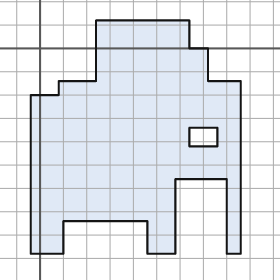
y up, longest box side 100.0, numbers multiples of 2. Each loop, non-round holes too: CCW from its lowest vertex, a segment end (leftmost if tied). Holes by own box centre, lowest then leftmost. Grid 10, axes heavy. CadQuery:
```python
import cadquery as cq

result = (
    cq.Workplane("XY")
    .moveTo(-4.0, -88.0)
    .lineTo(10.0, -88.0)
    .lineTo(10.0, -74.0)
    .lineTo(46.0, -74.0)
    .lineTo(46.0, -88.0)
    .lineTo(58.0, -88.0)
    .lineTo(58.0, -56.0)
    .lineTo(80.0, -56.0)
    .lineTo(80.0, -88.0)
    .lineTo(86.0, -88.0)
    .lineTo(86.0, -14.0)
    .lineTo(72.0, -14.0)
    .lineTo(72.0, 0.0)
    .lineTo(64.0, 0.0)
    .lineTo(64.0, 12.0)
    .lineTo(24.0, 12.0)
    .lineTo(24.0, -14.0)
    .lineTo(8.0, -14.0)
    .lineTo(8.0, -20.0)
    .lineTo(-4.0, -20.0)
    .close()
    .moveTo(64.0, -42.0)
    .lineTo(76.0, -42.0)
    .lineTo(76.0, -34.0)
    .lineTo(64.0, -34.0)
    .close()
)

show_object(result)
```